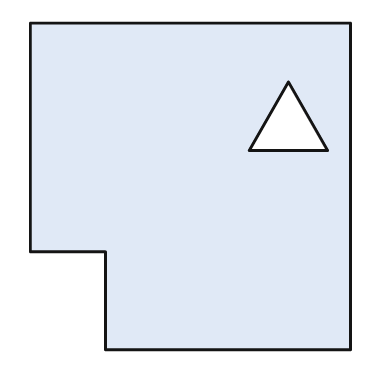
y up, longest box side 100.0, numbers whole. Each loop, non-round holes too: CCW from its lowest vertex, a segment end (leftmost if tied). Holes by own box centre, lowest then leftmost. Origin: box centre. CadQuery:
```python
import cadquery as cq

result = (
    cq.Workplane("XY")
    .moveTo(-26.0, -50.0)
    .lineTo(49.0, -50.0)
    .lineTo(49.0, 50.0)
    .lineTo(-49.0, 50.0)
    .lineTo(-49.0, -20.0)
    .lineTo(-26.0, -20.0)
    .close()
    .moveTo(18.0, 11.0)
    .lineTo(42.0, 11.0)
    .lineTo(30.0, 32.0)
    .close()
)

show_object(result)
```